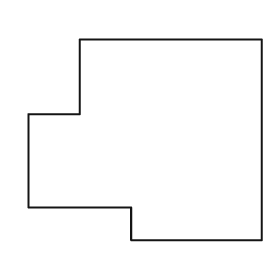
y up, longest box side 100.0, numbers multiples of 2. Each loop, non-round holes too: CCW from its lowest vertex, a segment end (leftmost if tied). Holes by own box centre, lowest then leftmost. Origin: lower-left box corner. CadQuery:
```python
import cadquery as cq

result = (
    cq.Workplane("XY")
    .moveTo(44.0, 0.0)
    .lineTo(100.0, 0.0)
    .lineTo(100.0, 86.0)
    .lineTo(22.0, 86.0)
    .lineTo(22.0, 54.0)
    .lineTo(0.0, 54.0)
    .lineTo(0.0, 14.0)
    .lineTo(44.0, 14.0)
    .close()
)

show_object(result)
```